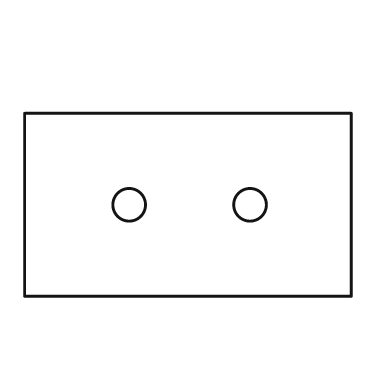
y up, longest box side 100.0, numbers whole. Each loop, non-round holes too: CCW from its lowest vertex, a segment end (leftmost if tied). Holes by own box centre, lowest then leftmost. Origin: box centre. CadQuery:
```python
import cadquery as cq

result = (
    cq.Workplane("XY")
    .moveTo(-50.0, -28.0)
    .lineTo(50.0, -28.0)
    .lineTo(50.0, 28.0)
    .lineTo(-50.0, 28.0)
    .close()
    .moveTo(-18.0, 0.0)
    .circle(5.0)
    .moveTo(19.0, 0.0)
    .circle(5.0)
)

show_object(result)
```